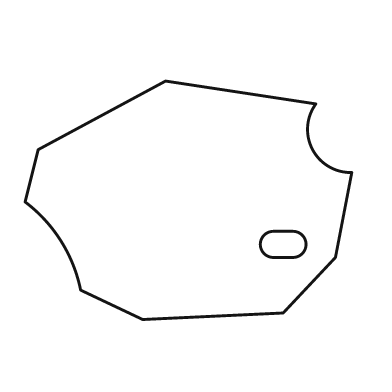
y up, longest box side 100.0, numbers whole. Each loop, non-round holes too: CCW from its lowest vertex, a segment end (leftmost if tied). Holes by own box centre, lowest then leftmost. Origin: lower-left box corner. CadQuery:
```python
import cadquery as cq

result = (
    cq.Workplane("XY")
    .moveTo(36.0, 0.0)
    .lineTo(79.0, 2.0)
    .lineTo(95.0, 19.0)
    .lineTo(100.0, 45.0)
    .threePointArc((88.0, 52.0), (89.0, 66.0))
    .lineTo(43.0, 73.0)
    .lineTo(4.0, 52.0)
    .lineTo(0.0, 36.0)
    .threePointArc((11.0, 24.0), (17.0, 9.0))
    .close()
    .moveTo(76.0, 19.0)
    .lineTo(82.0, 19.0)
    .threePointArc((86.0, 23.0), (82.0, 27.0))
    .lineTo(76.0, 27.0)
    .threePointArc((72.0, 23.0), (76.0, 19.0))
    .close()
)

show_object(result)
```